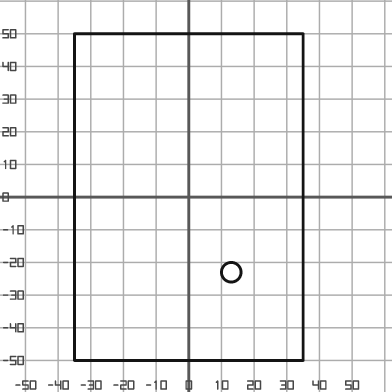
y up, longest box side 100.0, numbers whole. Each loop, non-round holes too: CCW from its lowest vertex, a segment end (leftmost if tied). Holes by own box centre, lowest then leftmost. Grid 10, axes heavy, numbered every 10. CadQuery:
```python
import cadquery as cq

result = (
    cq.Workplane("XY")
    .moveTo(-35.0, -50.0)
    .lineTo(35.0, -50.0)
    .lineTo(35.0, 50.0)
    .lineTo(-35.0, 50.0)
    .close()
    .moveTo(13.0, -23.0)
    .circle(3.0)
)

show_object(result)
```